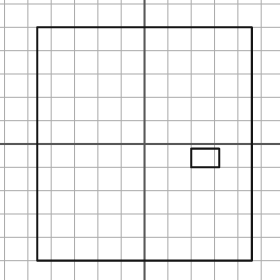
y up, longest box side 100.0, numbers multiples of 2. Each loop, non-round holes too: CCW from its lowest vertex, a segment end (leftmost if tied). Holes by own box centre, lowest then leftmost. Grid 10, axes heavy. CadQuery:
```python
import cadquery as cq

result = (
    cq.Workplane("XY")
    .moveTo(-46.0, -50.0)
    .lineTo(46.0, -50.0)
    .lineTo(46.0, 50.0)
    .lineTo(-46.0, 50.0)
    .close()
    .moveTo(20.0, -10.0)
    .lineTo(32.0, -10.0)
    .lineTo(32.0, -2.0)
    .lineTo(20.0, -2.0)
    .close()
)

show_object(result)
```